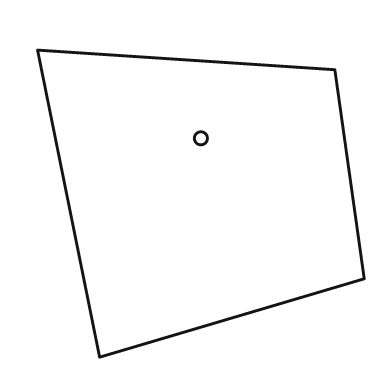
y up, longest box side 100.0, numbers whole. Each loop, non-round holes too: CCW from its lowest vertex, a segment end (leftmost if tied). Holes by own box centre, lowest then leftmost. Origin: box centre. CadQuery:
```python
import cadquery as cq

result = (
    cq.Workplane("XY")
    .moveTo(-31.0, -47.0)
    .lineTo(50.0, -23.0)
    .lineTo(41.0, 41.0)
    .lineTo(-50.0, 47.0)
    .close()
    .moveTo(0.0, 20.0)
    .circle(2.0)
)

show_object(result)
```